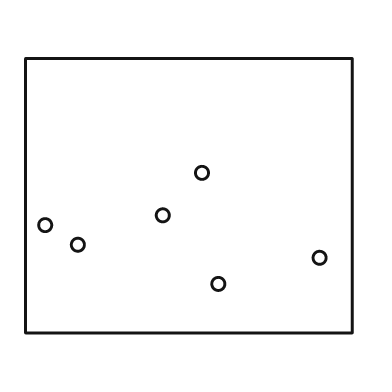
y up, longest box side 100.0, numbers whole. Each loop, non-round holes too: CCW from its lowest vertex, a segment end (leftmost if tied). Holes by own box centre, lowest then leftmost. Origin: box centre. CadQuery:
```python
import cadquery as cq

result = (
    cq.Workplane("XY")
    .moveTo(-50.0, -42.0)
    .lineTo(50.0, -42.0)
    .lineTo(50.0, 42.0)
    .lineTo(-50.0, 42.0)
    .close()
    .moveTo(9.0, -27.0)
    .circle(2.0)
    .moveTo(40.0, -19.0)
    .circle(2.0)
    .moveTo(-34.0, -15.0)
    .circle(2.0)
    .moveTo(-44.0, -9.0)
    .circle(2.0)
    .moveTo(-8.0, -6.0)
    .circle(2.0)
    .moveTo(4.0, 7.0)
    .circle(2.0)
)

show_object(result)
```